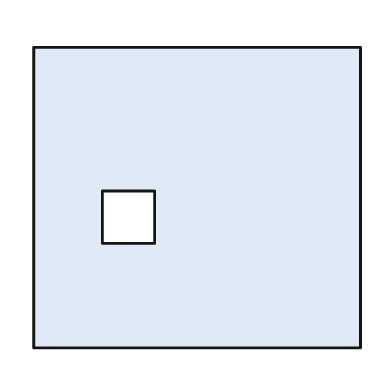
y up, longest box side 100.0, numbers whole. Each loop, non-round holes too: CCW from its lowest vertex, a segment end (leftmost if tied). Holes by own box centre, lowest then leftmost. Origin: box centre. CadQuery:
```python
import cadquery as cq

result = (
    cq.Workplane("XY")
    .moveTo(-50.0, -46.0)
    .lineTo(50.0, -46.0)
    .lineTo(50.0, 46.0)
    .lineTo(-50.0, 46.0)
    .close()
    .moveTo(-29.0, -14.0)
    .lineTo(-13.0, -14.0)
    .lineTo(-13.0, 2.0)
    .lineTo(-29.0, 2.0)
    .close()
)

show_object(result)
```